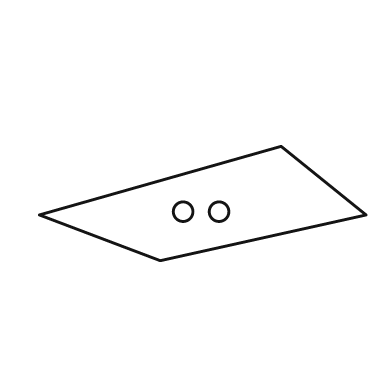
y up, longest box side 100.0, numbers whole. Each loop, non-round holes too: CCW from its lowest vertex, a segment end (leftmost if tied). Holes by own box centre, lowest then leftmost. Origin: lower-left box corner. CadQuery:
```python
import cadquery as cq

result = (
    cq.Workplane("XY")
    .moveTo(37.0, 0.0)
    .lineTo(100.0, 14.0)
    .lineTo(74.0, 35.0)
    .lineTo(0.0, 14.0)
    .close()
    .moveTo(44.0, 15.0)
    .circle(3.0)
    .moveTo(55.0, 15.0)
    .circle(3.0)
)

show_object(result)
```